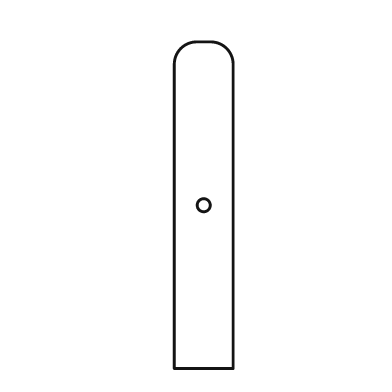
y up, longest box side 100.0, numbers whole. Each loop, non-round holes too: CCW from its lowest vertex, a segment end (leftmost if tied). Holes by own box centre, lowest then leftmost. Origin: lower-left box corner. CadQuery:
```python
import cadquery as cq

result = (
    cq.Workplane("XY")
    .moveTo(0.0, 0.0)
    .lineTo(18.0, 0.0)
    .lineTo(18.0, 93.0)
    .threePointArc((16.0, 98.0), (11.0, 100.0))
    .lineTo(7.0, 100.0)
    .threePointArc((2.0, 98.0), (0.0, 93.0))
    .close()
    .moveTo(9.0, 50.0)
    .circle(2.0)
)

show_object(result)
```